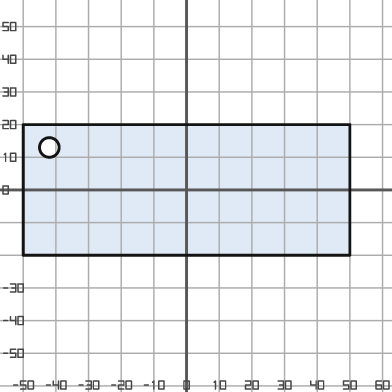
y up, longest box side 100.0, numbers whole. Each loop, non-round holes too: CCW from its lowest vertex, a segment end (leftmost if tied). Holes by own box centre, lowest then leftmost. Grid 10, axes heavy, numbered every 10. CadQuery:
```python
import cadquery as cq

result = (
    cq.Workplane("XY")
    .moveTo(-50.0, -20.0)
    .lineTo(50.0, -20.0)
    .lineTo(50.0, 20.0)
    .lineTo(-50.0, 20.0)
    .close()
    .moveTo(-42.0, 13.0)
    .circle(3.0)
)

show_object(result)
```